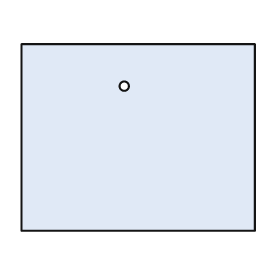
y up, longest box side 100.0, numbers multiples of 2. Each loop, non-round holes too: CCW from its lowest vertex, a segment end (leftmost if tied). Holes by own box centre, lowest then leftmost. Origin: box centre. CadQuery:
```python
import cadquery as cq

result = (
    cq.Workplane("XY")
    .moveTo(-50.0, -40.0)
    .lineTo(50.0, -40.0)
    .lineTo(50.0, 40.0)
    .lineTo(-50.0, 40.0)
    .close()
    .moveTo(-6.0, 22.0)
    .circle(2.0)
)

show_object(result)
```